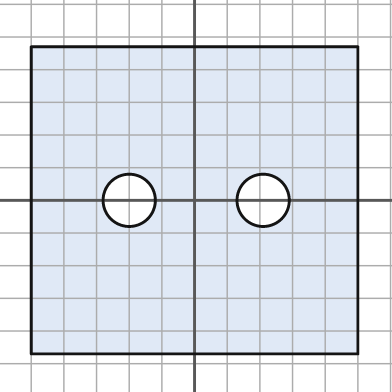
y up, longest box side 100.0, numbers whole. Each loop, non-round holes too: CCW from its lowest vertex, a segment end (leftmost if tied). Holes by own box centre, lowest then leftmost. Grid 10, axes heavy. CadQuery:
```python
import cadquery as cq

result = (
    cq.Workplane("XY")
    .moveTo(-50.0, -47.0)
    .lineTo(50.0, -47.0)
    .lineTo(50.0, 47.0)
    .lineTo(-50.0, 47.0)
    .close()
    .moveTo(-20.0, 0.0)
    .circle(8.0)
    .moveTo(21.0, 0.0)
    .circle(8.0)
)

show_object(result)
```